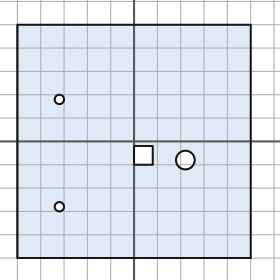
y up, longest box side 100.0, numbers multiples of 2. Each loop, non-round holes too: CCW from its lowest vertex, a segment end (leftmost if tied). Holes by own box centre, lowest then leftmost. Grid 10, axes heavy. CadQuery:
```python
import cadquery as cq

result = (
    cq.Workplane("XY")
    .moveTo(-50.0, -50.0)
    .lineTo(50.0, -50.0)
    .lineTo(50.0, 50.0)
    .lineTo(-50.0, 50.0)
    .close()
    .moveTo(-32.0, -28.0)
    .circle(2.0)
    .moveTo(22.0, -8.0)
    .circle(4.0)
    .moveTo(0.0, -10.0)
    .lineTo(8.0, -10.0)
    .lineTo(8.0, -2.0)
    .lineTo(0.0, -2.0)
    .close()
    .moveTo(-32.0, 18.0)
    .circle(2.0)
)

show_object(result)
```